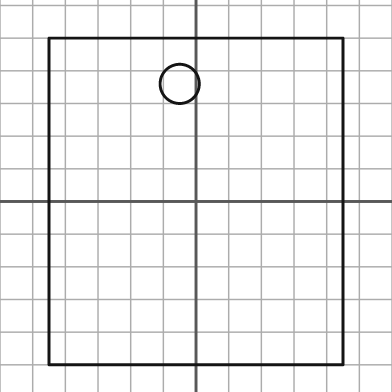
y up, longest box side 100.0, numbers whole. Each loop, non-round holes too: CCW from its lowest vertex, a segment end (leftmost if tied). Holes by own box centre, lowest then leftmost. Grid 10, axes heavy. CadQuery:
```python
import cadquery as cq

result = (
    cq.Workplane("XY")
    .moveTo(-45.0, -50.0)
    .lineTo(45.0, -50.0)
    .lineTo(45.0, 50.0)
    .lineTo(-45.0, 50.0)
    .close()
    .moveTo(-5.0, 36.0)
    .circle(6.0)
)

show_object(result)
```